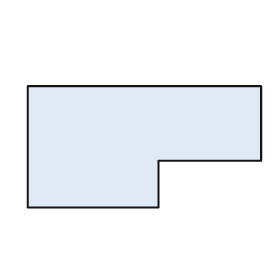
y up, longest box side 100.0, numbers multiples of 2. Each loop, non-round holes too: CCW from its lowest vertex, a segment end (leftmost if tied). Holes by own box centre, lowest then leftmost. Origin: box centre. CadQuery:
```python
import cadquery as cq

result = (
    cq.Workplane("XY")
    .moveTo(-50.0, -26.0)
    .lineTo(6.0, -26.0)
    .lineTo(6.0, -6.0)
    .lineTo(50.0, -6.0)
    .lineTo(50.0, 26.0)
    .lineTo(-50.0, 26.0)
    .close()
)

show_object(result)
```